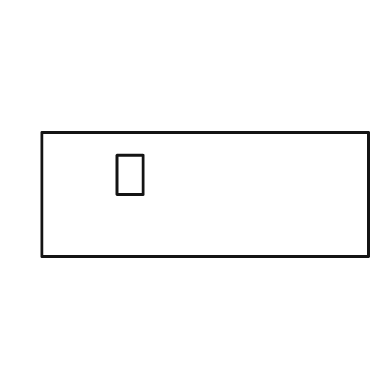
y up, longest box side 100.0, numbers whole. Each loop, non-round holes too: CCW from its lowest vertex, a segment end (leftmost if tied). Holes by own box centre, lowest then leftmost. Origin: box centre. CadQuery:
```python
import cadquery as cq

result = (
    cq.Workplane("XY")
    .moveTo(-50.0, -19.0)
    .lineTo(50.0, -19.0)
    .lineTo(50.0, 19.0)
    .lineTo(-50.0, 19.0)
    .close()
    .moveTo(-27.0, 0.0)
    .lineTo(-19.0, 0.0)
    .lineTo(-19.0, 12.0)
    .lineTo(-27.0, 12.0)
    .close()
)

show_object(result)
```